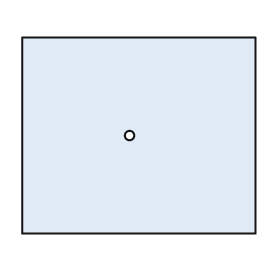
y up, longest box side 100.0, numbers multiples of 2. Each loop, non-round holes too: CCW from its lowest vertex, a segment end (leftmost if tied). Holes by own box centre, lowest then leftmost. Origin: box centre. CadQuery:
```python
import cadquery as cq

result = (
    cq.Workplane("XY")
    .moveTo(-50.0, -42.0)
    .lineTo(50.0, -42.0)
    .lineTo(50.0, 42.0)
    .lineTo(-50.0, 42.0)
    .close()
    .moveTo(-4.0, 0.0)
    .circle(2.0)
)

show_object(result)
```